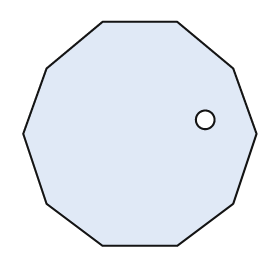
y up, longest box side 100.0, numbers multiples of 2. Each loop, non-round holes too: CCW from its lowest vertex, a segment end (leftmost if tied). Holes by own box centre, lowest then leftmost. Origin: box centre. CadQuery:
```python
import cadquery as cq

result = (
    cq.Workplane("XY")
    .moveTo(-16.0, -48.0)
    .lineTo(16.0, -48.0)
    .lineTo(40.0, -30.0)
    .lineTo(50.0, 0.0)
    .lineTo(40.0, 28.0)
    .lineTo(16.0, 48.0)
    .lineTo(-16.0, 48.0)
    .lineTo(-40.0, 28.0)
    .lineTo(-50.0, 0.0)
    .lineTo(-40.0, -30.0)
    .close()
    .moveTo(28.0, 6.0)
    .circle(4.0)
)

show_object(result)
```